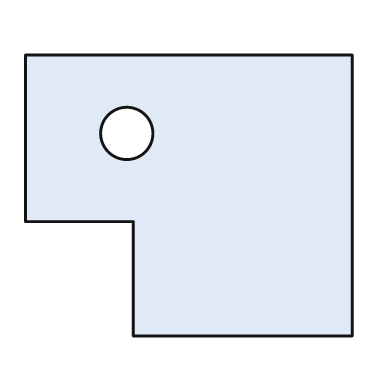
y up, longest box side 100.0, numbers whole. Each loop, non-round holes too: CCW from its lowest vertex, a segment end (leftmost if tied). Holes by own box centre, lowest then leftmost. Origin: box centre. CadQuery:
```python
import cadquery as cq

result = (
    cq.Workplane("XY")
    .moveTo(-17.0, -43.0)
    .lineTo(50.0, -43.0)
    .lineTo(50.0, 43.0)
    .lineTo(-50.0, 43.0)
    .lineTo(-50.0, -8.0)
    .lineTo(-17.0, -8.0)
    .close()
    .moveTo(-19.0, 19.0)
    .circle(8.0)
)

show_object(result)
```